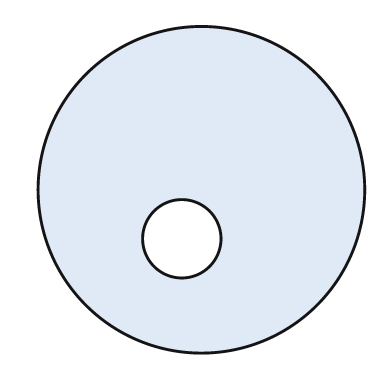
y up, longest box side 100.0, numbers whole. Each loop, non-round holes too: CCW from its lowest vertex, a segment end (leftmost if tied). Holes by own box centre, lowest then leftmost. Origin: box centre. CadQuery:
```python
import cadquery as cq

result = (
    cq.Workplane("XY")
    .moveTo(0.0, 0.0)
    .circle(50.0)
    .moveTo(-6.0, -15.0)
    .circle(12.0)
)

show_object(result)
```